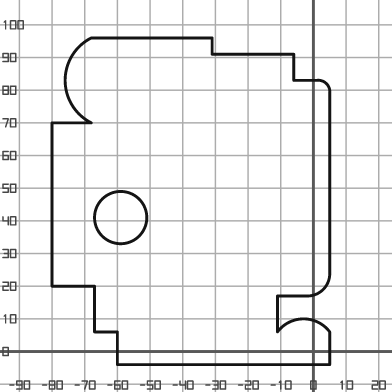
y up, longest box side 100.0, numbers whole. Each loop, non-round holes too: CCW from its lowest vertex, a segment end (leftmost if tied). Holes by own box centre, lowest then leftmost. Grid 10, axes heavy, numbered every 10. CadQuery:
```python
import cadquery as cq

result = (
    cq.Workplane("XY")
    .moveTo(-60.0, -4.0)
    .lineTo(5.0, -4.0)
    .lineTo(5.0, 6.0)
    .threePointArc((-3.0, 10.0), (-11.0, 6.0))
    .lineTo(-11.0, 17.0)
    .lineTo(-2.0, 17.0)
    .threePointArc((3.0, 19.0), (5.0, 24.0))
    .lineTo(5.0, 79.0)
    .threePointArc((4.0, 82.0), (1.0, 83.0))
    .lineTo(-6.0, 83.0)
    .lineTo(-6.0, 91.0)
    .lineTo(-31.0, 91.0)
    .lineTo(-31.0, 96.0)
    .lineTo(-68.0, 96.0)
    .threePointArc((-76.0, 83.0), (-68.0, 70.0))
    .lineTo(-80.0, 70.0)
    .lineTo(-80.0, 20.0)
    .lineTo(-67.0, 20.0)
    .lineTo(-67.0, 6.0)
    .lineTo(-60.0, 6.0)
    .close()
    .moveTo(-59.0, 41.0)
    .circle(8.0)
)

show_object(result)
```